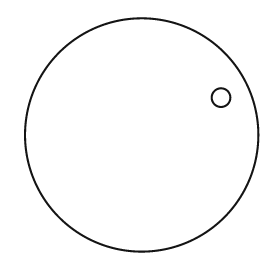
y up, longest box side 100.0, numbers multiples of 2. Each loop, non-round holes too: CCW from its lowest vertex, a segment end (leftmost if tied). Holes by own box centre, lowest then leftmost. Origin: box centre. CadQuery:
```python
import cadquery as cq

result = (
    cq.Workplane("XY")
    .moveTo(0.0, 0.0)
    .circle(50.0)
    .moveTo(34.0, 16.0)
    .circle(4.0)
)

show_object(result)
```